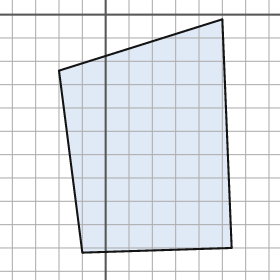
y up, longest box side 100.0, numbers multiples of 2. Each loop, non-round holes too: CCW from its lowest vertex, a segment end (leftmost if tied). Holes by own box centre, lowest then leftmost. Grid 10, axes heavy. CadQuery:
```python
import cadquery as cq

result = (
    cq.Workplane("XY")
    .moveTo(-10.0, -102.0)
    .lineTo(54.0, -100.0)
    .lineTo(50.0, -2.0)
    .lineTo(-20.0, -24.0)
    .close()
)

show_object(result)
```